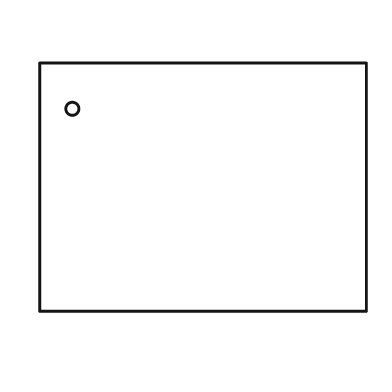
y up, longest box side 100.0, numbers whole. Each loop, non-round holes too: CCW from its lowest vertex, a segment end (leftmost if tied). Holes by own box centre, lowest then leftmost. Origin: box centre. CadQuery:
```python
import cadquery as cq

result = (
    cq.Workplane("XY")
    .moveTo(-50.0, -38.0)
    .lineTo(50.0, -38.0)
    .lineTo(50.0, 38.0)
    .lineTo(-50.0, 38.0)
    .close()
    .moveTo(-40.0, 24.0)
    .circle(2.0)
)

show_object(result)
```